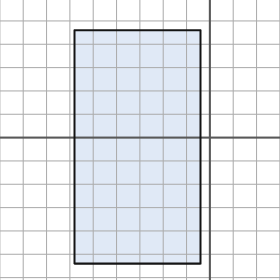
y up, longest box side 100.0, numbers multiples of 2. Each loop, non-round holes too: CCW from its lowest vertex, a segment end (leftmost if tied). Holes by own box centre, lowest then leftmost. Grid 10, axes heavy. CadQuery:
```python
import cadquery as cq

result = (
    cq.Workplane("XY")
    .moveTo(-58.0, -54.0)
    .lineTo(-4.0, -54.0)
    .lineTo(-4.0, 46.0)
    .lineTo(-58.0, 46.0)
    .close()
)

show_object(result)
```